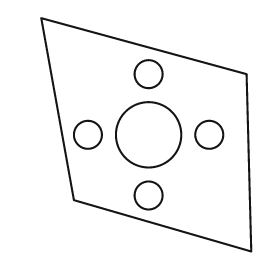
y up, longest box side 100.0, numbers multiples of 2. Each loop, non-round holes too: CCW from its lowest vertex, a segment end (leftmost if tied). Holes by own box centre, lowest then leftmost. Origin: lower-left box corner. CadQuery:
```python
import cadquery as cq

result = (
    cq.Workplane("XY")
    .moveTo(90.0, 0.0)
    .lineTo(88.0, 76.0)
    .lineTo(0.0, 100.0)
    .lineTo(14.0, 22.0)
    .close()
    .moveTo(46.0, 24.0)
    .circle(6.0)
    .moveTo(20.0, 50.0)
    .circle(6.0)
    .moveTo(46.0, 50.0)
    .circle(14.0)
    .moveTo(72.0, 50.0)
    .circle(6.0)
    .moveTo(46.0, 76.0)
    .circle(6.0)
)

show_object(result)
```